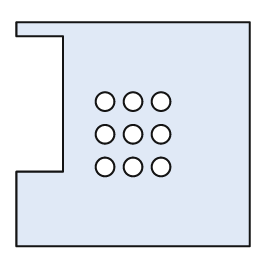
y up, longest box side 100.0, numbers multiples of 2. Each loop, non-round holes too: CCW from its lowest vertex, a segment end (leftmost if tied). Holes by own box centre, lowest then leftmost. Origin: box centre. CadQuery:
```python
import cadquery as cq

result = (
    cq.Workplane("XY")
    .moveTo(-50.0, -48.0)
    .lineTo(50.0, -48.0)
    .lineTo(50.0, 48.0)
    .lineTo(-50.0, 48.0)
    .lineTo(-50.0, 42.0)
    .lineTo(-30.0, 42.0)
    .lineTo(-30.0, -16.0)
    .lineTo(-50.0, -16.0)
    .close()
    .moveTo(-12.0, -14.0)
    .circle(4.0)
    .moveTo(0.0, -14.0)
    .circle(4.0)
    .moveTo(12.0, -14.0)
    .circle(4.0)
    .moveTo(-12.0, 0.0)
    .circle(4.0)
    .moveTo(0.0, 0.0)
    .circle(4.0)
    .moveTo(12.0, 0.0)
    .circle(4.0)
    .moveTo(-12.0, 14.0)
    .circle(4.0)
    .moveTo(0.0, 14.0)
    .circle(4.0)
    .moveTo(12.0, 14.0)
    .circle(4.0)
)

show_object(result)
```